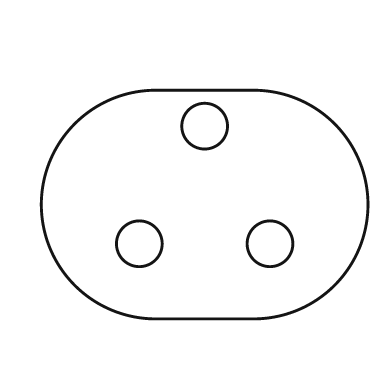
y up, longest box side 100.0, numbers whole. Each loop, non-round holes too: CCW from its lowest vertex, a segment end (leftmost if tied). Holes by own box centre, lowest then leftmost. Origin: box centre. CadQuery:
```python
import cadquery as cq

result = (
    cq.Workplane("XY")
    .moveTo(-15.0, -35.0)
    .lineTo(15.0, -35.0)
    .threePointArc((50.0, 0.0), (15.0, 35.0))
    .lineTo(-15.0, 35.0)
    .threePointArc((-50.0, 0.0), (-15.0, -35.0))
    .close()
    .moveTo(-20.0, -12.0)
    .circle(7.0)
    .moveTo(20.0, -12.0)
    .circle(7.0)
    .moveTo(0.0, 24.0)
    .circle(7.0)
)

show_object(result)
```